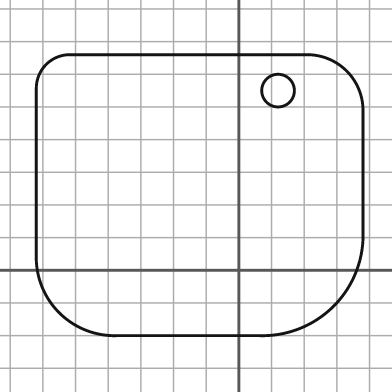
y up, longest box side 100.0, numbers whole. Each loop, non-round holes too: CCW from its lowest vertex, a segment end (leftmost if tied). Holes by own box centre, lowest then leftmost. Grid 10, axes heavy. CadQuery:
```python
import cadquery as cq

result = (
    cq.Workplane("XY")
    .moveTo(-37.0, -20.0)
    .lineTo(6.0, -20.0)
    .threePointArc((29.0, -11.0), (38.0, 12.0))
    .lineTo(38.0, 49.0)
    .threePointArc((33.0, 61.0), (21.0, 66.0))
    .lineTo(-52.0, 66.0)
    .threePointArc((-59.0, 63.0), (-62.0, 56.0))
    .lineTo(-62.0, 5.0)
    .threePointArc((-55.0, -13.0), (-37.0, -20.0))
    .close()
    .moveTo(12.0, 55.0)
    .circle(5.0)
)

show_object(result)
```